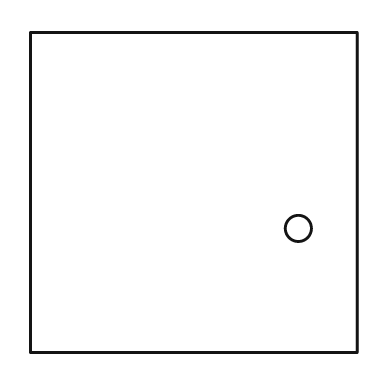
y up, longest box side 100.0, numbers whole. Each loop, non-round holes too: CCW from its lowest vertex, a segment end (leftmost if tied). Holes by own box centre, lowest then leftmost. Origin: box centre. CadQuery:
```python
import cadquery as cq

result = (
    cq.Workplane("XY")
    .moveTo(-50.0, -49.0)
    .lineTo(50.0, -49.0)
    .lineTo(50.0, 49.0)
    .lineTo(-50.0, 49.0)
    .close()
    .moveTo(32.0, -11.0)
    .circle(4.0)
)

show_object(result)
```